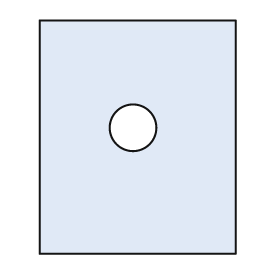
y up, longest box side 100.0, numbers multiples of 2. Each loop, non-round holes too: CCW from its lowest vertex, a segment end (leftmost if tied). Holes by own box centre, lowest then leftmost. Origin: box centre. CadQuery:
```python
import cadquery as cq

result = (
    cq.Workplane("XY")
    .moveTo(-42.0, -50.0)
    .lineTo(42.0, -50.0)
    .lineTo(42.0, 50.0)
    .lineTo(-42.0, 50.0)
    .close()
    .moveTo(-2.0, 4.0)
    .circle(10.0)
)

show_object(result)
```